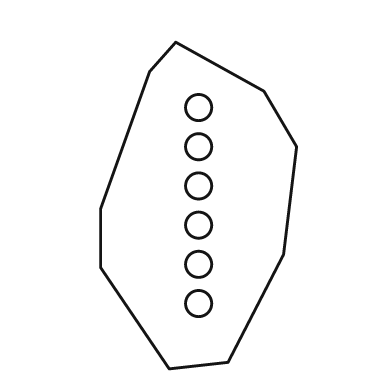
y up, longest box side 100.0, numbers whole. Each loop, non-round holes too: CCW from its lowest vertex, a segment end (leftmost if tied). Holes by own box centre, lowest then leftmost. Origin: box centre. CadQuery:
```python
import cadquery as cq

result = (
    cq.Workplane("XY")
    .moveTo(-9.0, -50.0)
    .lineTo(9.0, -48.0)
    .lineTo(26.0, -15.0)
    .lineTo(30.0, 18.0)
    .lineTo(20.0, 35.0)
    .lineTo(-7.0, 50.0)
    .lineTo(-15.0, 41.0)
    .lineTo(-30.0, -1.0)
    .lineTo(-30.0, -19.0)
    .close()
    .moveTo(0.0, -30.0)
    .circle(4.0)
    .moveTo(0.0, -18.0)
    .circle(4.0)
    .moveTo(0.0, -6.0)
    .circle(4.0)
    .moveTo(0.0, 6.0)
    .circle(4.0)
    .moveTo(0.0, 18.0)
    .circle(4.0)
    .moveTo(0.0, 30.0)
    .circle(4.0)
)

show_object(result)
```